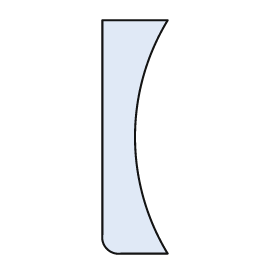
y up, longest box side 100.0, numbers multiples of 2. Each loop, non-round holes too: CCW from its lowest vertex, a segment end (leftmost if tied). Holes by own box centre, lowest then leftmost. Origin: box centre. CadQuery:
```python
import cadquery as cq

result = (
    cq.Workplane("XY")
    .moveTo(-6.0, -50.0)
    .lineTo(14.0, -50.0)
    .threePointArc((0.0, 0.0), (14.0, 50.0))
    .lineTo(-14.0, 50.0)
    .lineTo(-14.0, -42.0)
    .threePointArc((-12.0, -48.0), (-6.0, -50.0))
    .close()
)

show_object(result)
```